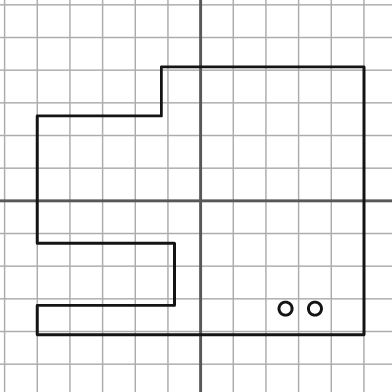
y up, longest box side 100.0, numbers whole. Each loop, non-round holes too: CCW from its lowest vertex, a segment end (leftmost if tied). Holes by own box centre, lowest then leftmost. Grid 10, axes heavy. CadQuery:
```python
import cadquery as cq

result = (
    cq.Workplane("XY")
    .moveTo(-50.0, -41.0)
    .lineTo(50.0, -41.0)
    .lineTo(50.0, 41.0)
    .lineTo(-12.0, 41.0)
    .lineTo(-12.0, 26.0)
    .lineTo(-50.0, 26.0)
    .lineTo(-50.0, -13.0)
    .lineTo(-8.0, -13.0)
    .lineTo(-8.0, -32.0)
    .lineTo(-50.0, -32.0)
    .close()
    .moveTo(26.0, -33.0)
    .circle(2.0)
    .moveTo(35.0, -33.0)
    .circle(2.0)
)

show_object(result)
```